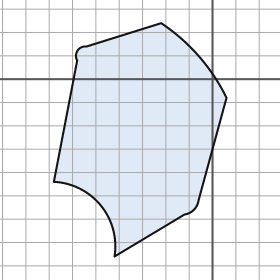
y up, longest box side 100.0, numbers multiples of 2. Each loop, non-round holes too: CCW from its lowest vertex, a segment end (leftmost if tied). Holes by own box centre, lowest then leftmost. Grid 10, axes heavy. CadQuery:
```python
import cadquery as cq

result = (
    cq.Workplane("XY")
    .moveTo(-42.0, -76.0)
    .lineTo(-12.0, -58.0)
    .threePointArc((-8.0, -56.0), (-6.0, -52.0))
    .lineTo(6.0, -8.0)
    .threePointArc((-6.0, 10.0), (-22.0, 24.0))
    .lineTo(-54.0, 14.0)
    .threePointArc((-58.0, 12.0), (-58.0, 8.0))
    .lineTo(-68.0, -44.0)
    .threePointArc((-48.0, -54.0), (-42.0, -76.0))
    .close()
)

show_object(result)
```